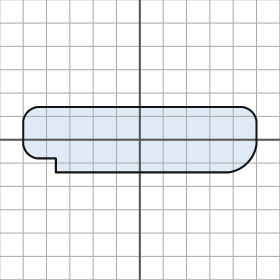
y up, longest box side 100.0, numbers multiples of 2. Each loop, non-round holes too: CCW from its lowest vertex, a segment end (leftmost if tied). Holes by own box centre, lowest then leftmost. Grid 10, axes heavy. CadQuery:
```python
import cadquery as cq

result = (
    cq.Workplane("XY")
    .moveTo(-36.0, -14.0)
    .lineTo(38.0, -14.0)
    .threePointArc((46.0, -10.0), (50.0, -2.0))
    .lineTo(50.0, 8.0)
    .threePointArc((48.0, 12.0), (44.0, 14.0))
    .lineTo(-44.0, 14.0)
    .threePointArc((-48.0, 12.0), (-50.0, 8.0))
    .lineTo(-50.0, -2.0)
    .threePointArc((-48.0, -6.0), (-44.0, -8.0))
    .lineTo(-36.0, -8.0)
    .close()
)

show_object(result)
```